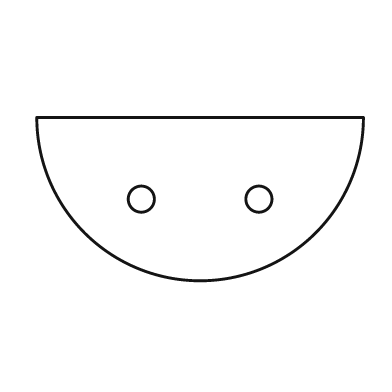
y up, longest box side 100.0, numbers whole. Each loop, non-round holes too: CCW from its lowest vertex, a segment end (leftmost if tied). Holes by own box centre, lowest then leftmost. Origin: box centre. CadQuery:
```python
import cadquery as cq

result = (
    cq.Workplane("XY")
    .moveTo(-50.0, 25.0)
    .threePointArc((0.0, -25.0), (50.0, 25.0))
    .close()
    .moveTo(-18.0, 0.0)
    .circle(4.0)
    .moveTo(18.0, 0.0)
    .circle(4.0)
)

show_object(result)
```